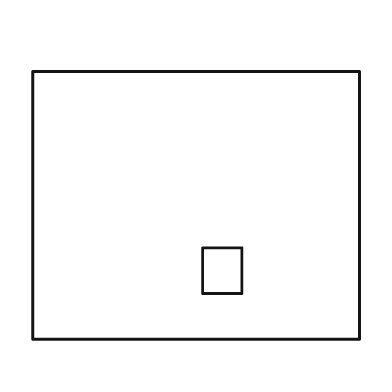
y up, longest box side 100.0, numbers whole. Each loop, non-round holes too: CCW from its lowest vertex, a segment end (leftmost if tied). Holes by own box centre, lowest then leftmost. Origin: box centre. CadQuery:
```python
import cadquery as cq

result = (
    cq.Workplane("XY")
    .moveTo(-50.0, -41.0)
    .lineTo(50.0, -41.0)
    .lineTo(50.0, 41.0)
    .lineTo(-50.0, 41.0)
    .close()
    .moveTo(2.0, -27.0)
    .lineTo(14.0, -27.0)
    .lineTo(14.0, -13.0)
    .lineTo(2.0, -13.0)
    .close()
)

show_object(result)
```